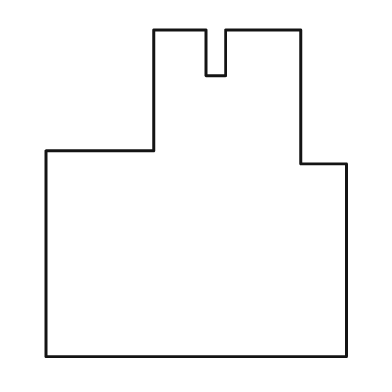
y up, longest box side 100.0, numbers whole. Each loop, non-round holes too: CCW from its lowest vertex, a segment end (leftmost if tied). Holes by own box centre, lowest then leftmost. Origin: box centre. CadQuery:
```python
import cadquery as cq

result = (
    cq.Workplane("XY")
    .moveTo(-46.0, -50.0)
    .lineTo(46.0, -50.0)
    .lineTo(46.0, 9.0)
    .lineTo(32.0, 9.0)
    .lineTo(32.0, 50.0)
    .lineTo(9.0, 50.0)
    .lineTo(9.0, 36.0)
    .lineTo(3.0, 36.0)
    .lineTo(3.0, 50.0)
    .lineTo(-13.0, 50.0)
    .lineTo(-13.0, 13.0)
    .lineTo(-46.0, 13.0)
    .close()
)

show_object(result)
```